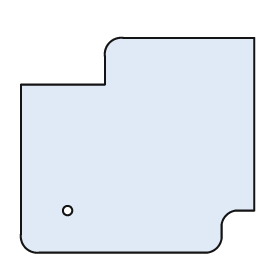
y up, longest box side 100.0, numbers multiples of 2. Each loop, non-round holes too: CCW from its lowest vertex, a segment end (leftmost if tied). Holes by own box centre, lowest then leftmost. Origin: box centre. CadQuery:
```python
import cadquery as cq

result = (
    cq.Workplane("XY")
    .moveTo(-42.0, -46.0)
    .lineTo(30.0, -46.0)
    .threePointArc((34.0, -44.0), (36.0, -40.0))
    .lineTo(36.0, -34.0)
    .threePointArc((38.0, -30.0), (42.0, -28.0))
    .lineTo(50.0, -28.0)
    .lineTo(50.0, 46.0)
    .lineTo(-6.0, 46.0)
    .threePointArc((-12.0, 44.0), (-14.0, 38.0))
    .lineTo(-14.0, 26.0)
    .lineTo(-50.0, 26.0)
    .lineTo(-50.0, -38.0)
    .threePointArc((-48.0, -44.0), (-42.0, -46.0))
    .close()
    .moveTo(-30.0, -28.0)
    .circle(2.0)
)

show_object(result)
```